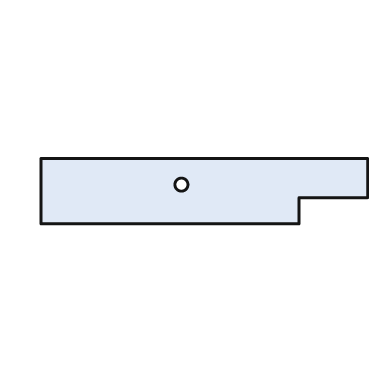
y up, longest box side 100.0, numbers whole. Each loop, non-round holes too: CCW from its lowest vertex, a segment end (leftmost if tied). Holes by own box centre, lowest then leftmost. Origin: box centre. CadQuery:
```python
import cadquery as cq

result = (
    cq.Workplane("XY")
    .moveTo(-50.0, -10.0)
    .lineTo(29.0, -10.0)
    .lineTo(29.0, -2.0)
    .lineTo(50.0, -2.0)
    .lineTo(50.0, 10.0)
    .lineTo(-50.0, 10.0)
    .close()
    .moveTo(-7.0, 2.0)
    .circle(2.0)
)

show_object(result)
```